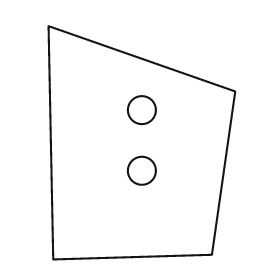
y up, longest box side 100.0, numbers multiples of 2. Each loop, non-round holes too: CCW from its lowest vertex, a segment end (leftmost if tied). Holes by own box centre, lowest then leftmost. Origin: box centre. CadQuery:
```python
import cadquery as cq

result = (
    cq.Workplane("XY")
    .moveTo(-38.0, -50.0)
    .lineTo(30.0, -48.0)
    .lineTo(40.0, 22.0)
    .lineTo(-40.0, 50.0)
    .close()
    .moveTo(0.0, -12.0)
    .circle(6.0)
    .moveTo(0.0, 14.0)
    .circle(6.0)
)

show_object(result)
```